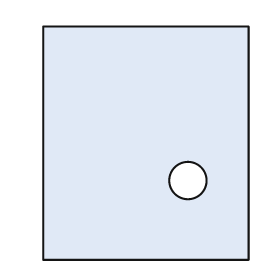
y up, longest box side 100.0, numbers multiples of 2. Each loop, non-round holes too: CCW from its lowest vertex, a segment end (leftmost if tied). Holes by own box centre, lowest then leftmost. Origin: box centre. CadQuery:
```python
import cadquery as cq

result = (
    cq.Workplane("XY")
    .moveTo(-44.0, -50.0)
    .lineTo(44.0, -50.0)
    .lineTo(44.0, 50.0)
    .lineTo(-44.0, 50.0)
    .close()
    .moveTo(18.0, -16.0)
    .circle(8.0)
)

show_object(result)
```